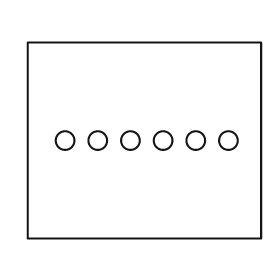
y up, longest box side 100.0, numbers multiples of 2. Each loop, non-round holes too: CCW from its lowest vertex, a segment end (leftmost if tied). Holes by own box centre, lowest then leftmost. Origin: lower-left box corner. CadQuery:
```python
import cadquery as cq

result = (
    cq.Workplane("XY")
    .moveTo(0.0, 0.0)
    .lineTo(100.0, 0.0)
    .lineTo(100.0, 84.0)
    .lineTo(0.0, 84.0)
    .close()
    .moveTo(16.0, 42.0)
    .circle(4.0)
    .moveTo(30.0, 42.0)
    .circle(4.0)
    .moveTo(44.0, 42.0)
    .circle(4.0)
    .moveTo(58.0, 42.0)
    .circle(4.0)
    .moveTo(72.0, 42.0)
    .circle(4.0)
    .moveTo(86.0, 42.0)
    .circle(4.0)
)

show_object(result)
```